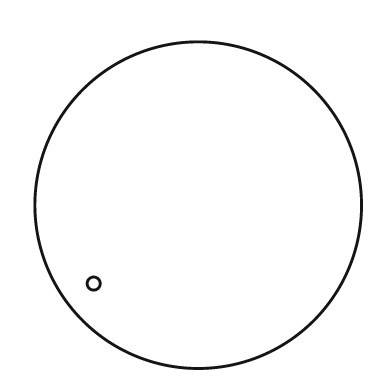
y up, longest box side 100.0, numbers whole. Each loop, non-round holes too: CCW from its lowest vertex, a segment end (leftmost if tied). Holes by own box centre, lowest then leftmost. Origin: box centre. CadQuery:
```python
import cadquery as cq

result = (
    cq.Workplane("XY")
    .moveTo(0.0, 0.0)
    .circle(50.0)
    .moveTo(-32.0, -24.0)
    .circle(2.0)
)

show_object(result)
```